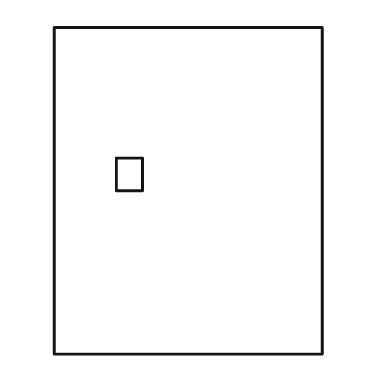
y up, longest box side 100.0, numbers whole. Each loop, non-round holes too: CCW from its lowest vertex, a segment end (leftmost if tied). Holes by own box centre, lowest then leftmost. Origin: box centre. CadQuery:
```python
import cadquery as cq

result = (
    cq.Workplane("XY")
    .moveTo(-41.0, -50.0)
    .lineTo(41.0, -50.0)
    .lineTo(41.0, 50.0)
    .lineTo(-41.0, 50.0)
    .close()
    .moveTo(-22.0, 0.0)
    .lineTo(-14.0, 0.0)
    .lineTo(-14.0, 10.0)
    .lineTo(-22.0, 10.0)
    .close()
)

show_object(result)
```